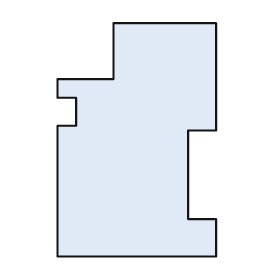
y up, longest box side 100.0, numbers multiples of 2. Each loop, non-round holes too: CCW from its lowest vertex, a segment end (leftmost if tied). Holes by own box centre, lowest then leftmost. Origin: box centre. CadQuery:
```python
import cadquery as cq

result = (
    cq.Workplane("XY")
    .moveTo(-34.0, -50.0)
    .lineTo(34.0, -50.0)
    .lineTo(34.0, -34.0)
    .lineTo(22.0, -34.0)
    .lineTo(22.0, 4.0)
    .lineTo(34.0, 4.0)
    .lineTo(34.0, 50.0)
    .lineTo(-10.0, 50.0)
    .lineTo(-10.0, 26.0)
    .lineTo(-34.0, 26.0)
    .lineTo(-34.0, 18.0)
    .lineTo(-26.0, 18.0)
    .lineTo(-26.0, 6.0)
    .lineTo(-34.0, 6.0)
    .close()
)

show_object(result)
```